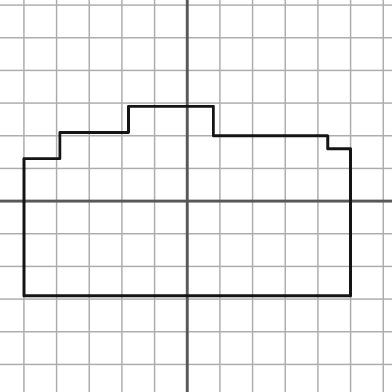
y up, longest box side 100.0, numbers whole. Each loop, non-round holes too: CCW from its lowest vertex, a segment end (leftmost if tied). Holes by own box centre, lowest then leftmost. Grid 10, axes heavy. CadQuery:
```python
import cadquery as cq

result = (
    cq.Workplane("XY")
    .moveTo(-50.0, -29.0)
    .lineTo(50.0, -29.0)
    .lineTo(50.0, 16.0)
    .lineTo(43.0, 16.0)
    .lineTo(43.0, 20.0)
    .lineTo(8.0, 20.0)
    .lineTo(8.0, 29.0)
    .lineTo(-18.0, 29.0)
    .lineTo(-18.0, 21.0)
    .lineTo(-39.0, 21.0)
    .lineTo(-39.0, 13.0)
    .lineTo(-50.0, 13.0)
    .close()
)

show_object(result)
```